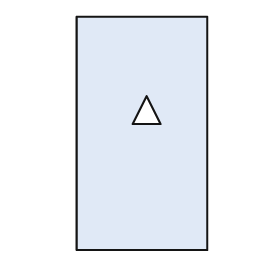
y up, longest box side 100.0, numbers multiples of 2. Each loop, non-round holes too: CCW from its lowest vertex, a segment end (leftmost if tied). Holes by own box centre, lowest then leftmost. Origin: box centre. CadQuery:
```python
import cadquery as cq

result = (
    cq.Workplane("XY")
    .moveTo(-28.0, -50.0)
    .lineTo(28.0, -50.0)
    .lineTo(28.0, 50.0)
    .lineTo(-28.0, 50.0)
    .close()
    .moveTo(-4.0, 4.0)
    .lineTo(8.0, 4.0)
    .lineTo(2.0, 16.0)
    .close()
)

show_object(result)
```